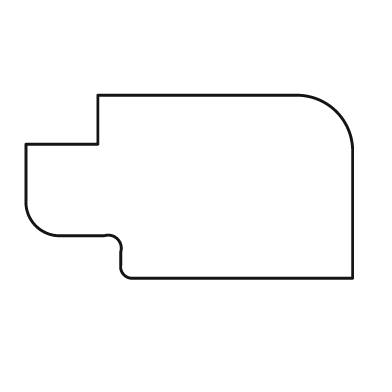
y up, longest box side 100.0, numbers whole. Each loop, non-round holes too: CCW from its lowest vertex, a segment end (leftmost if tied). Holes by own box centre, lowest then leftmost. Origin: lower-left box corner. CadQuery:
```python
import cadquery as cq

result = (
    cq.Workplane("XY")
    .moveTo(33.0, 0.0)
    .lineTo(100.0, 0.0)
    .lineTo(100.0, 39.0)
    .threePointArc((95.0, 51.0), (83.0, 56.0))
    .lineTo(22.0, 56.0)
    .lineTo(22.0, 41.0)
    .lineTo(0.0, 41.0)
    .lineTo(0.0, 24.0)
    .threePointArc((3.0, 16.0), (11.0, 13.0))
    .lineTo(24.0, 13.0)
    .threePointArc((28.0, 12.0), (29.0, 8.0))
    .lineTo(29.0, 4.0)
    .threePointArc((30.0, 1.0), (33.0, 0.0))
    .close()
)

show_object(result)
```